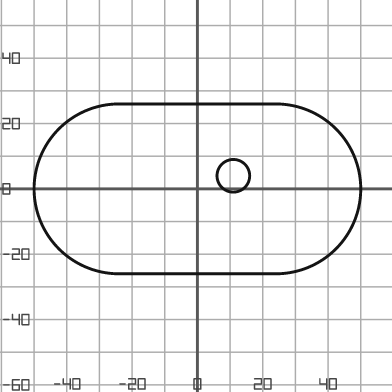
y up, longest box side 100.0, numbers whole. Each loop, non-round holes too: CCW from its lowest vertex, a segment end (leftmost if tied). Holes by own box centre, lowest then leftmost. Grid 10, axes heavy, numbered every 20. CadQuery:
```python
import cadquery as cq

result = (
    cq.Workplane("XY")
    .moveTo(-24.0, -26.0)
    .lineTo(24.0, -26.0)
    .threePointArc((50.0, 0.0), (24.0, 26.0))
    .lineTo(-24.0, 26.0)
    .threePointArc((-50.0, 0.0), (-24.0, -26.0))
    .close()
    .moveTo(11.0, 4.0)
    .circle(5.0)
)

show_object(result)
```